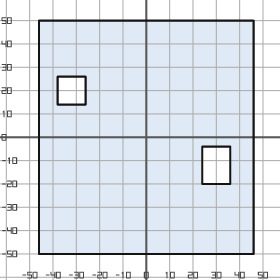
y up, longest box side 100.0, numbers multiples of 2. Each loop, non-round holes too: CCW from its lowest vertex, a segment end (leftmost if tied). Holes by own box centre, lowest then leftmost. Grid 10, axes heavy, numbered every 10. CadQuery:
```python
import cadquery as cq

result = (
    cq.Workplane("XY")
    .moveTo(-46.0, -50.0)
    .lineTo(46.0, -50.0)
    .lineTo(46.0, 50.0)
    .lineTo(-46.0, 50.0)
    .close()
    .moveTo(24.0, -20.0)
    .lineTo(36.0, -20.0)
    .lineTo(36.0, -4.0)
    .lineTo(24.0, -4.0)
    .close()
    .moveTo(-38.0, 14.0)
    .lineTo(-26.0, 14.0)
    .lineTo(-26.0, 26.0)
    .lineTo(-38.0, 26.0)
    .close()
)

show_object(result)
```